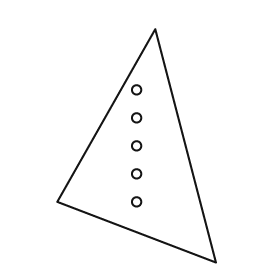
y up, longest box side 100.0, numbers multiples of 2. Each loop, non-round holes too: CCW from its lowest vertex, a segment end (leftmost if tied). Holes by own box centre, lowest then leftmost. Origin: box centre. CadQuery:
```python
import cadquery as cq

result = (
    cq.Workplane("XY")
    .moveTo(34.0, -50.0)
    .lineTo(8.0, 50.0)
    .lineTo(-34.0, -24.0)
    .close()
    .moveTo(0.0, -24.0)
    .circle(2.0)
    .moveTo(0.0, -12.0)
    .circle(2.0)
    .moveTo(0.0, 0.0)
    .circle(2.0)
    .moveTo(0.0, 12.0)
    .circle(2.0)
    .moveTo(0.0, 24.0)
    .circle(2.0)
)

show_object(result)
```